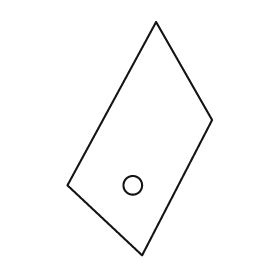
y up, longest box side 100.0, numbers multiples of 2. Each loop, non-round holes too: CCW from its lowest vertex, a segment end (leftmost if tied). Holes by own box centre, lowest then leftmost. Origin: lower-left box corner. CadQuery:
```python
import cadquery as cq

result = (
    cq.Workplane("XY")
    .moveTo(32.0, 0.0)
    .lineTo(62.0, 58.0)
    .lineTo(38.0, 100.0)
    .lineTo(0.0, 30.0)
    .close()
    .moveTo(28.0, 30.0)
    .circle(4.0)
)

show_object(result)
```